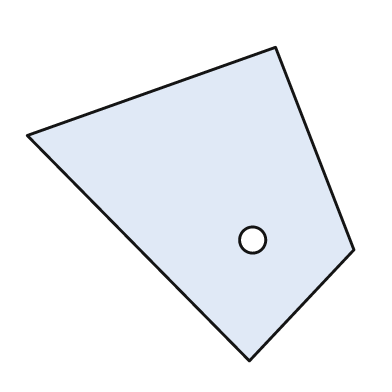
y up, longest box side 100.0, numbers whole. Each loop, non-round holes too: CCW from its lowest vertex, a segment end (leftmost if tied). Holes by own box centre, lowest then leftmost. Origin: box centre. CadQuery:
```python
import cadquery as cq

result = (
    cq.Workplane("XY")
    .moveTo(18.0, -48.0)
    .lineTo(50.0, -14.0)
    .lineTo(26.0, 48.0)
    .lineTo(-50.0, 21.0)
    .close()
    .moveTo(19.0, -11.0)
    .circle(4.0)
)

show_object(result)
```